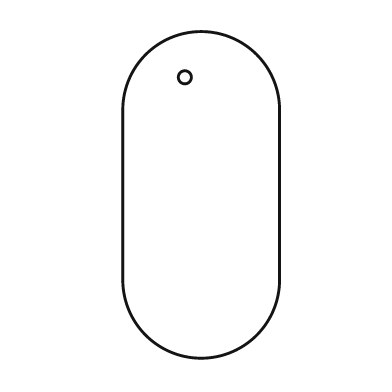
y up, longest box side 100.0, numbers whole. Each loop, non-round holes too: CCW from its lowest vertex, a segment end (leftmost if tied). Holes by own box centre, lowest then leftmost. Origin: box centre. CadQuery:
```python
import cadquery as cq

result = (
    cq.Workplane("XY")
    .moveTo(-24.0, -26.0)
    .threePointArc((0.0, -50.0), (24.0, -26.0))
    .lineTo(24.0, 26.0)
    .threePointArc((0.0, 50.0), (-24.0, 26.0))
    .close()
    .moveTo(-5.0, 36.0)
    .circle(2.0)
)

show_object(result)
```